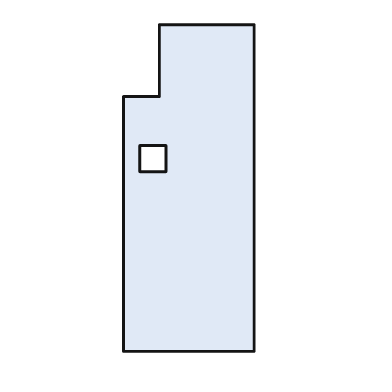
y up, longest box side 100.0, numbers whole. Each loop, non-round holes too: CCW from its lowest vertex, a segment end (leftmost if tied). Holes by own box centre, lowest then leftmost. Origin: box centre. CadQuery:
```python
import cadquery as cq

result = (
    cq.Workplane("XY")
    .moveTo(-20.0, -50.0)
    .lineTo(20.0, -50.0)
    .lineTo(20.0, 50.0)
    .lineTo(-9.0, 50.0)
    .lineTo(-9.0, 28.0)
    .lineTo(-20.0, 28.0)
    .close()
    .moveTo(-15.0, 5.0)
    .lineTo(-7.0, 5.0)
    .lineTo(-7.0, 13.0)
    .lineTo(-15.0, 13.0)
    .close()
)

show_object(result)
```